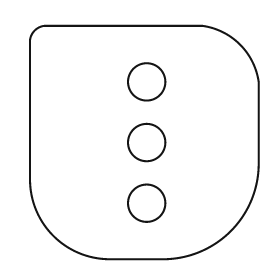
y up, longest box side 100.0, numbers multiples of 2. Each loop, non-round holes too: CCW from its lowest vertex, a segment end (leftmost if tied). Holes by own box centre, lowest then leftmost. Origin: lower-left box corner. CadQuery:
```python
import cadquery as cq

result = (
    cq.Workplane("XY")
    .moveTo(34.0, 0.0)
    .lineTo(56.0, 0.0)
    .threePointArc((86.0, 12.0), (98.0, 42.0))
    .lineTo(98.0, 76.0)
    .threePointArc((90.0, 92.0), (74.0, 100.0))
    .lineTo(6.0, 100.0)
    .threePointArc((2.0, 98.0), (0.0, 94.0))
    .lineTo(0.0, 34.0)
    .threePointArc((10.0, 10.0), (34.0, 0.0))
    .close()
    .moveTo(50.0, 24.0)
    .circle(8.0)
    .moveTo(50.0, 50.0)
    .circle(8.0)
    .moveTo(50.0, 76.0)
    .circle(8.0)
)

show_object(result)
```